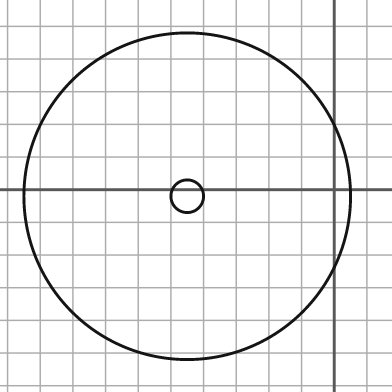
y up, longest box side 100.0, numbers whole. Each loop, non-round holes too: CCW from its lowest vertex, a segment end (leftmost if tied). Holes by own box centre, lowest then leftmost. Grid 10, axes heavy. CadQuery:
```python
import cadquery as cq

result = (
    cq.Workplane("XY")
    .moveTo(-45.0, -2.0)
    .circle(50.0)
    .moveTo(-45.0, -2.0)
    .circle(5.0)
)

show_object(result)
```